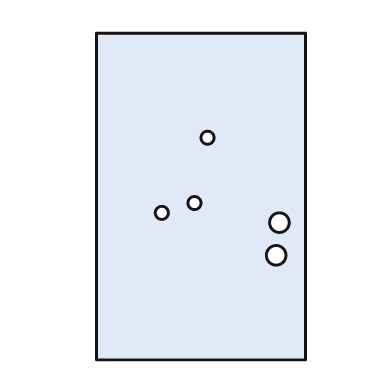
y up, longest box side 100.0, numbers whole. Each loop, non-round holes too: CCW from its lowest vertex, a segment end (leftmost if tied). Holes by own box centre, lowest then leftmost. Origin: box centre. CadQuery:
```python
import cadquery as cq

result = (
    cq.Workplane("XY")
    .moveTo(-32.0, -50.0)
    .lineTo(32.0, -50.0)
    .lineTo(32.0, 50.0)
    .lineTo(-32.0, 50.0)
    .close()
    .moveTo(23.0, -18.0)
    .circle(3.0)
    .moveTo(24.0, -8.0)
    .circle(3.0)
    .moveTo(-12.0, -5.0)
    .circle(2.0)
    .moveTo(-2.0, -2.0)
    .circle(2.0)
    .moveTo(2.0, 18.0)
    .circle(2.0)
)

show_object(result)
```